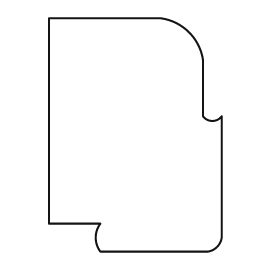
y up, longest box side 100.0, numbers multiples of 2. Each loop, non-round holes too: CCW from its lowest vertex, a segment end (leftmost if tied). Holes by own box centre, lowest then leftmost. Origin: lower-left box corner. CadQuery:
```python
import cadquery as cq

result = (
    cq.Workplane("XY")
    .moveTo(22.0, 0.0)
    .lineTo(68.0, 0.0)
    .threePointArc((72.0, 2.0), (74.0, 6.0))
    .lineTo(74.0, 58.0)
    .threePointArc((70.0, 56.0), (66.0, 58.0))
    .lineTo(66.0, 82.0)
    .threePointArc((60.0, 94.0), (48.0, 100.0))
    .lineTo(0.0, 100.0)
    .lineTo(0.0, 12.0)
    .lineTo(22.0, 12.0)
    .threePointArc((20.0, 6.0), (22.0, 0.0))
    .close()
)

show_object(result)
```